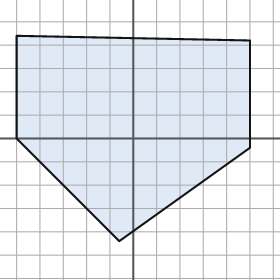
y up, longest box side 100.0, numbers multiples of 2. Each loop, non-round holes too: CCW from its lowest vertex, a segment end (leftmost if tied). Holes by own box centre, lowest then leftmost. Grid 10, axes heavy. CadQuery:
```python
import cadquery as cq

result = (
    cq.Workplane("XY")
    .moveTo(-6.0, -44.0)
    .lineTo(50.0, -4.0)
    .lineTo(50.0, 42.0)
    .lineTo(-50.0, 44.0)
    .lineTo(-50.0, 0.0)
    .close()
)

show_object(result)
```